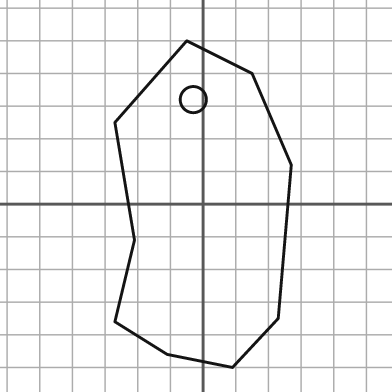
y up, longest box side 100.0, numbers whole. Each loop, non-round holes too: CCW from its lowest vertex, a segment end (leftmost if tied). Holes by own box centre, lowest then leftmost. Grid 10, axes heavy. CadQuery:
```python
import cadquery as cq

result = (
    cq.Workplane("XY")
    .moveTo(9.0, -50.0)
    .lineTo(23.0, -35.0)
    .lineTo(27.0, 12.0)
    .lineTo(15.0, 40.0)
    .lineTo(-5.0, 50.0)
    .lineTo(-27.0, 25.0)
    .lineTo(-21.0, -11.0)
    .lineTo(-27.0, -36.0)
    .lineTo(-11.0, -46.0)
    .close()
    .moveTo(-3.0, 32.0)
    .circle(4.0)
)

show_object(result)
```